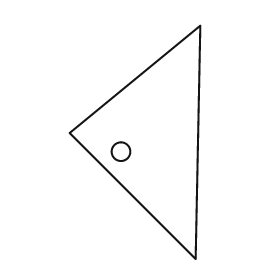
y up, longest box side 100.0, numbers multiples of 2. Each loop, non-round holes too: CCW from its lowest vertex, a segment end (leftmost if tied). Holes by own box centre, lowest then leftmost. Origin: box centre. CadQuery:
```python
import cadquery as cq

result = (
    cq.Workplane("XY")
    .moveTo(26.0, -50.0)
    .lineTo(28.0, 50.0)
    .lineTo(-28.0, 4.0)
    .close()
    .moveTo(-6.0, -4.0)
    .circle(4.0)
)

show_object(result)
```